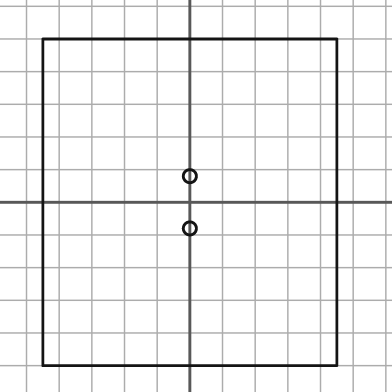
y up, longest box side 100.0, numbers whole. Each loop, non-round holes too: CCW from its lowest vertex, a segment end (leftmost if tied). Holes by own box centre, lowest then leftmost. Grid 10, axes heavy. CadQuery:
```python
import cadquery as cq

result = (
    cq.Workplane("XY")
    .moveTo(-45.0, -50.0)
    .lineTo(45.0, -50.0)
    .lineTo(45.0, 50.0)
    .lineTo(-45.0, 50.0)
    .close()
    .moveTo(0.0, -8.0)
    .circle(2.0)
    .moveTo(0.0, 8.0)
    .circle(2.0)
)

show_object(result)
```